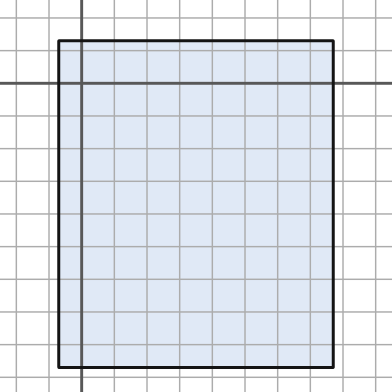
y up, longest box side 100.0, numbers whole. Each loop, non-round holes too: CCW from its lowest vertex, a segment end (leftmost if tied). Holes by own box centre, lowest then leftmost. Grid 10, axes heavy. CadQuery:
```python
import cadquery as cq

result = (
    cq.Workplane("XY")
    .moveTo(-7.0, -87.0)
    .lineTo(77.0, -87.0)
    .lineTo(77.0, 13.0)
    .lineTo(-7.0, 13.0)
    .close()
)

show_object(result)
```